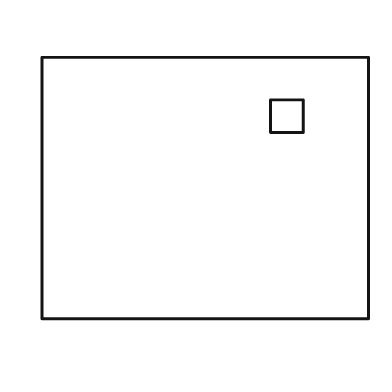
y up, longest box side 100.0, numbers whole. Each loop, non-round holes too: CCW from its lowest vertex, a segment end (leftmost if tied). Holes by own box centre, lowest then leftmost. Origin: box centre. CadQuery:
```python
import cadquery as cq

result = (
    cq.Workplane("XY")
    .moveTo(-50.0, -40.0)
    .lineTo(50.0, -40.0)
    .lineTo(50.0, 40.0)
    .lineTo(-50.0, 40.0)
    .close()
    .moveTo(20.0, 17.0)
    .lineTo(30.0, 17.0)
    .lineTo(30.0, 27.0)
    .lineTo(20.0, 27.0)
    .close()
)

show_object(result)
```